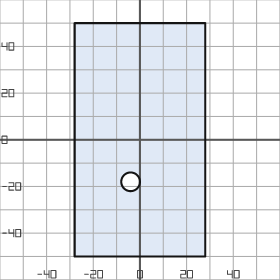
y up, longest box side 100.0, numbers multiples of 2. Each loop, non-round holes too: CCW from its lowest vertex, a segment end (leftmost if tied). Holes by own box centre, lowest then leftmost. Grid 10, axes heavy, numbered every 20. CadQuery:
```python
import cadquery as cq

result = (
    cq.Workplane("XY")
    .moveTo(-28.0, -50.0)
    .lineTo(28.0, -50.0)
    .lineTo(28.0, 50.0)
    .lineTo(-28.0, 50.0)
    .close()
    .moveTo(-4.0, -18.0)
    .circle(4.0)
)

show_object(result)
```